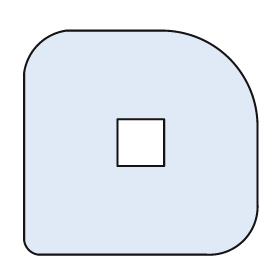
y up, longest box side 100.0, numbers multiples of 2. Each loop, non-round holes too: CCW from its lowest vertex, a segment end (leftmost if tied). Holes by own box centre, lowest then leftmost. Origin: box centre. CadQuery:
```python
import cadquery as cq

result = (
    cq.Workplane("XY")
    .moveTo(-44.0, -48.0)
    .lineTo(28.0, -48.0)
    .threePointArc((44.0, -42.0), (50.0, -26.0))
    .lineTo(50.0, 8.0)
    .threePointArc((38.0, 36.0), (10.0, 48.0))
    .lineTo(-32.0, 48.0)
    .threePointArc((-44.0, 42.0), (-50.0, 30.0))
    .lineTo(-50.0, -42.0)
    .threePointArc((-48.0, -46.0), (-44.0, -48.0))
    .close()
    .moveTo(-10.0, -10.0)
    .lineTo(10.0, -10.0)
    .lineTo(10.0, 10.0)
    .lineTo(-10.0, 10.0)
    .close()
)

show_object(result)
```